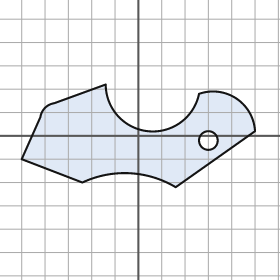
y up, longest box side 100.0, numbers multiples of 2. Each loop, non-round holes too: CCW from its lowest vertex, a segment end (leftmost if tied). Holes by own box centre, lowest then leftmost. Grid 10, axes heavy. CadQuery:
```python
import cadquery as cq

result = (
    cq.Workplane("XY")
    .moveTo(16.0, -22.0)
    .lineTo(50.0, 2.0)
    .threePointArc((42.0, 16.0), (26.0, 18.0))
    .threePointArc((4.0, 2.0), (-14.0, 22.0))
    .lineTo(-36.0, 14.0)
    .threePointArc((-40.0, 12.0), (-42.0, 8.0))
    .lineTo(-50.0, -10.0)
    .lineTo(-24.0, -20.0)
    .threePointArc((-4.0, -16.0), (16.0, -22.0))
    .close()
    .moveTo(30.0, -2.0)
    .circle(4.0)
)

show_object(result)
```